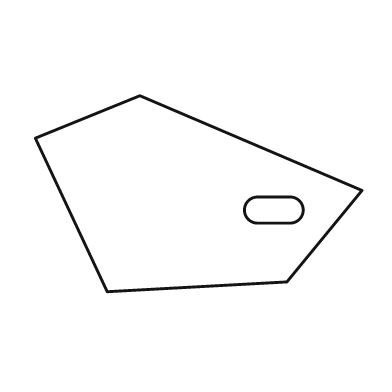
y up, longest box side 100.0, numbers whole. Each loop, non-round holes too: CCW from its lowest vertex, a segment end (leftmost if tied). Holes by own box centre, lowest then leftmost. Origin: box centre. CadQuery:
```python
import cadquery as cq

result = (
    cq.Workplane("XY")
    .moveTo(-28.0, -30.0)
    .lineTo(27.0, -27.0)
    .lineTo(50.0, 1.0)
    .lineTo(-18.0, 30.0)
    .lineTo(-50.0, 17.0)
    .close()
    .moveTo(18.0, -9.0)
    .lineTo(28.0, -9.0)
    .threePointArc((32.0, -5.0), (28.0, -1.0))
    .lineTo(18.0, -1.0)
    .threePointArc((14.0, -5.0), (18.0, -9.0))
    .close()
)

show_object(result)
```